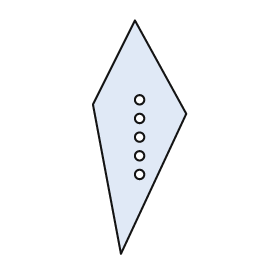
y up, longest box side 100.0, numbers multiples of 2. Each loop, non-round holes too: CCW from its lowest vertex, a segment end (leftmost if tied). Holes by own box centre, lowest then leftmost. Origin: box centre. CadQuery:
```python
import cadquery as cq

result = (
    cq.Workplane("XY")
    .moveTo(-8.0, -50.0)
    .lineTo(20.0, 10.0)
    .lineTo(-2.0, 50.0)
    .lineTo(-20.0, 14.0)
    .close()
    .moveTo(0.0, -16.0)
    .circle(2.0)
    .moveTo(0.0, -8.0)
    .circle(2.0)
    .moveTo(0.0, 0.0)
    .circle(2.0)
    .moveTo(0.0, 8.0)
    .circle(2.0)
    .moveTo(0.0, 16.0)
    .circle(2.0)
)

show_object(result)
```